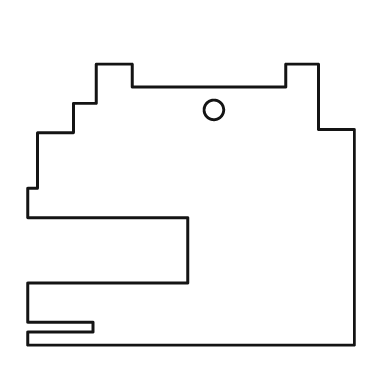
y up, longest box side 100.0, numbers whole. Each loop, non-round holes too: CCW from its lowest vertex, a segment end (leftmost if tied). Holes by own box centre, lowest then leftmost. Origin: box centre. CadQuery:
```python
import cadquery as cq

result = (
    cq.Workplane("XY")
    .moveTo(-50.0, -43.0)
    .lineTo(50.0, -43.0)
    .lineTo(50.0, 23.0)
    .lineTo(39.0, 23.0)
    .lineTo(39.0, 43.0)
    .lineTo(29.0, 43.0)
    .lineTo(29.0, 36.0)
    .lineTo(-18.0, 36.0)
    .lineTo(-18.0, 43.0)
    .lineTo(-29.0, 43.0)
    .lineTo(-29.0, 31.0)
    .lineTo(-36.0, 31.0)
    .lineTo(-36.0, 22.0)
    .lineTo(-47.0, 22.0)
    .lineTo(-47.0, 5.0)
    .lineTo(-50.0, 5.0)
    .lineTo(-50.0, -4.0)
    .lineTo(-1.0, -4.0)
    .lineTo(-1.0, -24.0)
    .lineTo(-50.0, -24.0)
    .lineTo(-50.0, -36.0)
    .lineTo(-30.0, -36.0)
    .lineTo(-30.0, -39.0)
    .lineTo(-50.0, -39.0)
    .close()
    .moveTo(7.0, 29.0)
    .circle(3.0)
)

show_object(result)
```